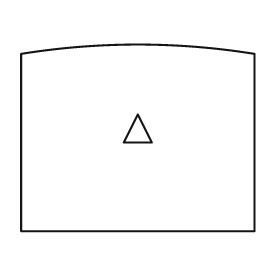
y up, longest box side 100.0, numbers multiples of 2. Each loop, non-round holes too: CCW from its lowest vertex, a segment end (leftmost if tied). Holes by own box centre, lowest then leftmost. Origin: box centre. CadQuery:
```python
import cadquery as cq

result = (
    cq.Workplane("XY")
    .moveTo(-50.0, -40.0)
    .lineTo(50.0, -40.0)
    .lineTo(50.0, 36.0)
    .threePointArc((0.0, 40.0), (-50.0, 36.0))
    .close()
    .moveTo(-6.0, -2.0)
    .lineTo(6.0, -2.0)
    .lineTo(0.0, 10.0)
    .close()
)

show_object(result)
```